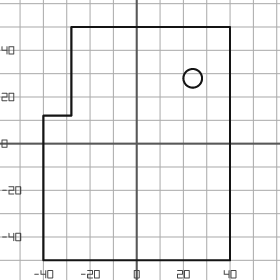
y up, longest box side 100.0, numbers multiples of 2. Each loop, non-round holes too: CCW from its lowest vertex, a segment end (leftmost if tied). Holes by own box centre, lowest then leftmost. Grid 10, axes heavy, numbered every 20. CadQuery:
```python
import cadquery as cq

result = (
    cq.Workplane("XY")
    .moveTo(-40.0, -50.0)
    .lineTo(40.0, -50.0)
    .lineTo(40.0, 50.0)
    .lineTo(-28.0, 50.0)
    .lineTo(-28.0, 12.0)
    .lineTo(-40.0, 12.0)
    .close()
    .moveTo(24.0, 28.0)
    .circle(4.0)
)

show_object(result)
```